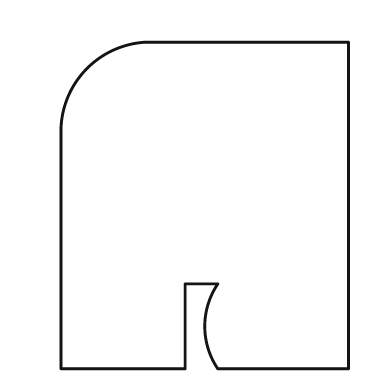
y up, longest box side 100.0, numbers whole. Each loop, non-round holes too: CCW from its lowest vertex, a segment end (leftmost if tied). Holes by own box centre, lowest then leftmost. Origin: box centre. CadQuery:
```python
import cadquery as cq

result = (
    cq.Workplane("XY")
    .moveTo(-44.0, -50.0)
    .lineTo(-6.0, -50.0)
    .lineTo(-6.0, -24.0)
    .lineTo(4.0, -24.0)
    .threePointArc((0.0, -37.0), (4.0, -50.0))
    .lineTo(44.0, -50.0)
    .lineTo(44.0, 50.0)
    .lineTo(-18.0, 50.0)
    .threePointArc((-36.0, 42.0), (-44.0, 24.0))
    .close()
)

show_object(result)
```